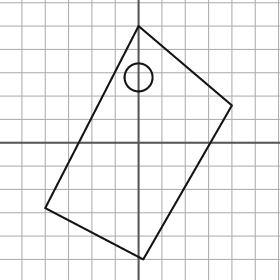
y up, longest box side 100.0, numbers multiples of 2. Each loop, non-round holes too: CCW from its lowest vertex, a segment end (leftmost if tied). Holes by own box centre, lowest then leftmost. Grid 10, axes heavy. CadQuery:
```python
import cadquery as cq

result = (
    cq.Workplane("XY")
    .moveTo(2.0, -50.0)
    .lineTo(40.0, 16.0)
    .lineTo(0.0, 50.0)
    .lineTo(-40.0, -28.0)
    .close()
    .moveTo(0.0, 28.0)
    .circle(6.0)
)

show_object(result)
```